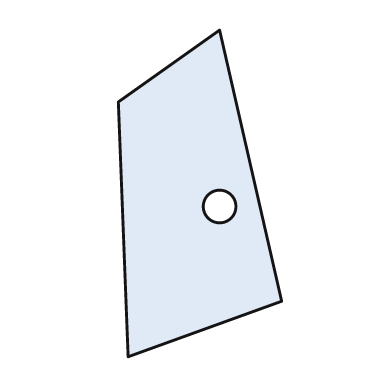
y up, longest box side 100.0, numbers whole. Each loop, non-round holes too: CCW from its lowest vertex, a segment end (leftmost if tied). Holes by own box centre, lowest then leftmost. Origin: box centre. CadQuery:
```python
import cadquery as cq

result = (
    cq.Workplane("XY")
    .moveTo(-22.0, -50.0)
    .lineTo(25.0, -33.0)
    .lineTo(6.0, 50.0)
    .lineTo(-25.0, 28.0)
    .close()
    .moveTo(6.0, -4.0)
    .circle(5.0)
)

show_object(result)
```